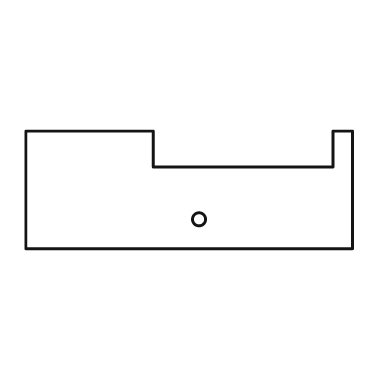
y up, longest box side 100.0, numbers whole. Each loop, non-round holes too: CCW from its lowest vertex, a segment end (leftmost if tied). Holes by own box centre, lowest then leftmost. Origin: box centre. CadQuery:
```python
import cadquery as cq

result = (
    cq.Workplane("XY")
    .moveTo(-50.0, -18.0)
    .lineTo(50.0, -18.0)
    .lineTo(50.0, 18.0)
    .lineTo(44.0, 18.0)
    .lineTo(44.0, 7.0)
    .lineTo(-11.0, 7.0)
    .lineTo(-11.0, 18.0)
    .lineTo(-50.0, 18.0)
    .close()
    .moveTo(3.0, -9.0)
    .circle(2.0)
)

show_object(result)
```